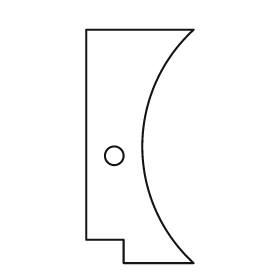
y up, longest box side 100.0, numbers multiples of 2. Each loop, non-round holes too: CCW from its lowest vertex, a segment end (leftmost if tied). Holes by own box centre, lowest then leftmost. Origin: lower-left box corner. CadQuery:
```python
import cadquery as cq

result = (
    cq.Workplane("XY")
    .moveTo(16.0, 0.0)
    .lineTo(46.0, 0.0)
    .threePointArc((24.0, 50.0), (46.0, 100.0))
    .lineTo(0.0, 100.0)
    .lineTo(0.0, 10.0)
    .lineTo(16.0, 10.0)
    .close()
    .moveTo(12.0, 46.0)
    .circle(4.0)
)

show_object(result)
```